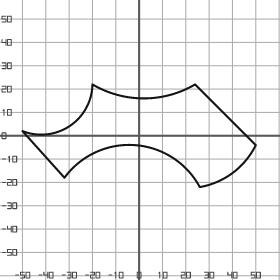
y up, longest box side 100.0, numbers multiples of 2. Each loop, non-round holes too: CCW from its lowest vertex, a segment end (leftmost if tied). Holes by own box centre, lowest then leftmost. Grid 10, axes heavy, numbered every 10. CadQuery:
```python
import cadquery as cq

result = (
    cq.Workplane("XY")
    .moveTo(26.0, -22.0)
    .threePointArc((40.0, -16.0), (50.0, -4.0))
    .lineTo(24.0, 22.0)
    .threePointArc((2.0, 16.0), (-20.0, 22.0))
    .threePointArc((-30.0, 4.0), (-50.0, 2.0))
    .lineTo(-32.0, -18.0)
    .threePointArc((-2.0, -4.0), (26.0, -22.0))
    .close()
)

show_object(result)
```